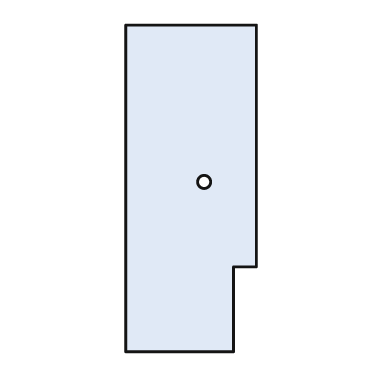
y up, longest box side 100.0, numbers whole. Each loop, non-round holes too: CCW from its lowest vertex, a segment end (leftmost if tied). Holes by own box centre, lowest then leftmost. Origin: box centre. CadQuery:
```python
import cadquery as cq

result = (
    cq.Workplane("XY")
    .moveTo(-20.0, -50.0)
    .lineTo(13.0, -50.0)
    .lineTo(13.0, -24.0)
    .lineTo(20.0, -24.0)
    .lineTo(20.0, 50.0)
    .lineTo(-20.0, 50.0)
    .close()
    .moveTo(4.0, 2.0)
    .circle(2.0)
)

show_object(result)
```